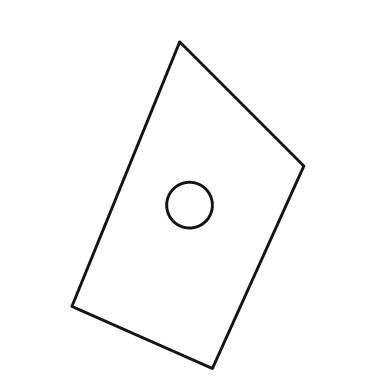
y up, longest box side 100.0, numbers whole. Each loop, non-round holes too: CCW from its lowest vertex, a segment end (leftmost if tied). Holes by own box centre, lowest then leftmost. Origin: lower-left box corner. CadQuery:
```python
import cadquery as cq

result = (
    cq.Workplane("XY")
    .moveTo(43.0, 0.0)
    .lineTo(71.0, 62.0)
    .lineTo(33.0, 100.0)
    .lineTo(0.0, 19.0)
    .close()
    .moveTo(36.0, 50.0)
    .circle(7.0)
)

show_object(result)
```